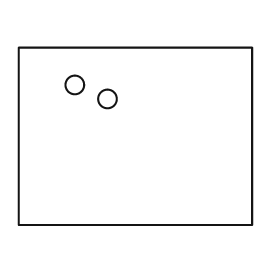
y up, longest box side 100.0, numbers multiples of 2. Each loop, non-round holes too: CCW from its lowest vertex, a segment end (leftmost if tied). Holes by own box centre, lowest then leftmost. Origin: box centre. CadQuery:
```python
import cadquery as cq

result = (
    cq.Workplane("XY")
    .moveTo(-50.0, -38.0)
    .lineTo(50.0, -38.0)
    .lineTo(50.0, 38.0)
    .lineTo(-50.0, 38.0)
    .close()
    .moveTo(-12.0, 16.0)
    .circle(4.0)
    .moveTo(-26.0, 22.0)
    .circle(4.0)
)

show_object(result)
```